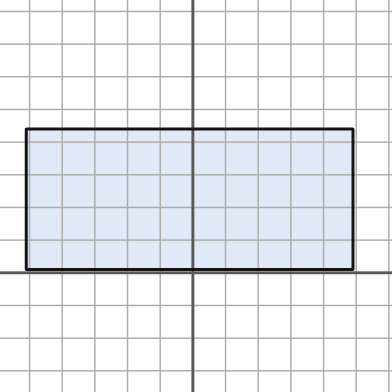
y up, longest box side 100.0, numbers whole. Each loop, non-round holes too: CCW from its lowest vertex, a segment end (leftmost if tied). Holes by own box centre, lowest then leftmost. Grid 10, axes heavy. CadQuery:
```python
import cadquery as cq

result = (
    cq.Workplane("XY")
    .moveTo(-51.0, 1.0)
    .lineTo(49.0, 1.0)
    .lineTo(49.0, 44.0)
    .lineTo(-51.0, 44.0)
    .close()
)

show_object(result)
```